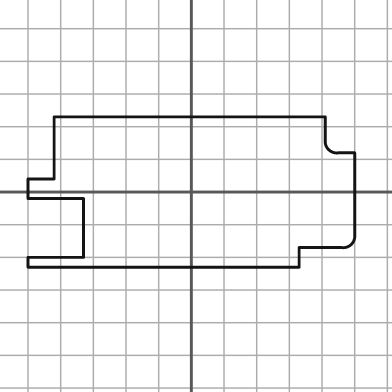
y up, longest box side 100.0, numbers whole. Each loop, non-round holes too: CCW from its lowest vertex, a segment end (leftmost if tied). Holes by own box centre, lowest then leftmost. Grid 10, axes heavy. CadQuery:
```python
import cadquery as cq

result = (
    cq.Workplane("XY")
    .moveTo(-50.0, -23.0)
    .lineTo(33.0, -23.0)
    .lineTo(33.0, -17.0)
    .lineTo(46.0, -17.0)
    .threePointArc((49.0, -16.0), (50.0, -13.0))
    .lineTo(50.0, 12.0)
    .lineTo(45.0, 12.0)
    .threePointArc((42.0, 13.0), (41.0, 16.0))
    .lineTo(41.0, 23.0)
    .lineTo(-42.0, 23.0)
    .lineTo(-42.0, 4.0)
    .lineTo(-50.0, 4.0)
    .lineTo(-50.0, -2.0)
    .lineTo(-33.0, -2.0)
    .lineTo(-33.0, -20.0)
    .lineTo(-50.0, -20.0)
    .close()
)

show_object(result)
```